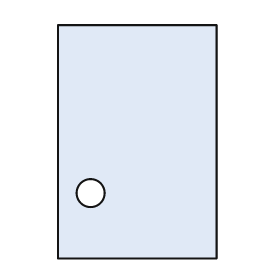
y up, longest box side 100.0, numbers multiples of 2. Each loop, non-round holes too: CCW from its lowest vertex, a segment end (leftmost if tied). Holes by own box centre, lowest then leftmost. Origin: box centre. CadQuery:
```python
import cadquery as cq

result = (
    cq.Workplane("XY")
    .moveTo(-34.0, -50.0)
    .lineTo(34.0, -50.0)
    .lineTo(34.0, 50.0)
    .lineTo(-34.0, 50.0)
    .close()
    .moveTo(-20.0, -22.0)
    .circle(6.0)
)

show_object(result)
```